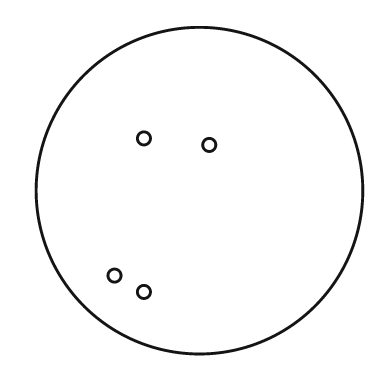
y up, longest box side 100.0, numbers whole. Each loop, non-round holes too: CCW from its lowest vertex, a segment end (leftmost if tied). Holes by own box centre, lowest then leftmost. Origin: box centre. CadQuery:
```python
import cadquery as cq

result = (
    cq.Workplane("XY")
    .moveTo(0.0, 0.0)
    .circle(50.0)
    .moveTo(-17.0, -31.0)
    .circle(2.0)
    .moveTo(-26.0, -26.0)
    .circle(2.0)
    .moveTo(3.0, 14.0)
    .circle(2.0)
    .moveTo(-17.0, 16.0)
    .circle(2.0)
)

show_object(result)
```